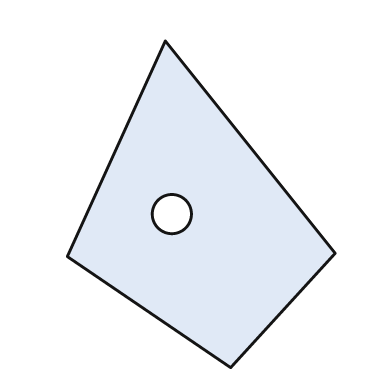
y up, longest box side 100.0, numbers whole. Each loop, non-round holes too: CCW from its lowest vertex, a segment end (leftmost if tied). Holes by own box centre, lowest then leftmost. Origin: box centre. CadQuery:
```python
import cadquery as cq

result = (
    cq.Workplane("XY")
    .moveTo(9.0, -50.0)
    .lineTo(41.0, -15.0)
    .lineTo(-11.0, 50.0)
    .lineTo(-41.0, -16.0)
    .close()
    .moveTo(-9.0, -3.0)
    .circle(6.0)
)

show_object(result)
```